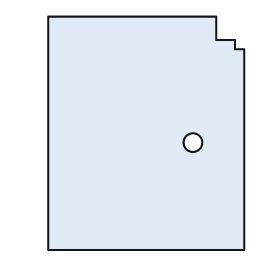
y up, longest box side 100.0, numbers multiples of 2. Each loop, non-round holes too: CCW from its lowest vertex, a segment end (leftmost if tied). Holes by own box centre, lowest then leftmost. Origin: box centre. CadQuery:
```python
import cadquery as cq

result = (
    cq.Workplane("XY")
    .moveTo(-42.0, -50.0)
    .lineTo(42.0, -50.0)
    .lineTo(42.0, 36.0)
    .lineTo(38.0, 36.0)
    .lineTo(38.0, 40.0)
    .lineTo(30.0, 40.0)
    .lineTo(30.0, 50.0)
    .lineTo(-42.0, 50.0)
    .close()
    .moveTo(20.0, -4.0)
    .circle(4.0)
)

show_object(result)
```